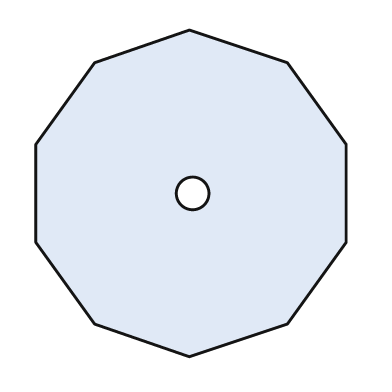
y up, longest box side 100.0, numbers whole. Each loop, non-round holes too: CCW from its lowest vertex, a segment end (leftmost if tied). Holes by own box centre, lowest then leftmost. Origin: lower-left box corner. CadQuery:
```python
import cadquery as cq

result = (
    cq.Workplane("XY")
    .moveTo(47.0, 0.0)
    .lineTo(77.0, 10.0)
    .lineTo(95.0, 35.0)
    .lineTo(95.0, 65.0)
    .lineTo(77.0, 90.0)
    .lineTo(47.0, 100.0)
    .lineTo(18.0, 90.0)
    .lineTo(0.0, 65.0)
    .lineTo(0.0, 35.0)
    .lineTo(18.0, 10.0)
    .close()
    .moveTo(48.0, 50.0)
    .circle(5.0)
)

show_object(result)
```